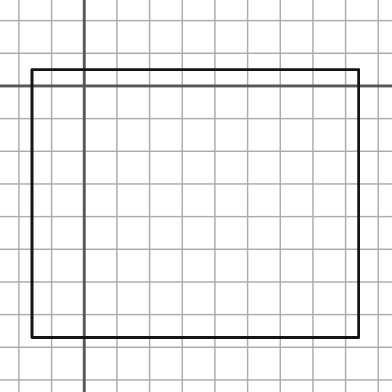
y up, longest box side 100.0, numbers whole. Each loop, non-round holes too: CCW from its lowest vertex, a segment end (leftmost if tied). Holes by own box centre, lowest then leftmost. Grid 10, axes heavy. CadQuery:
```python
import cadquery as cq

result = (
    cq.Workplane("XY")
    .moveTo(-16.0, -77.0)
    .lineTo(84.0, -77.0)
    .lineTo(84.0, 5.0)
    .lineTo(-16.0, 5.0)
    .close()
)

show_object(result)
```